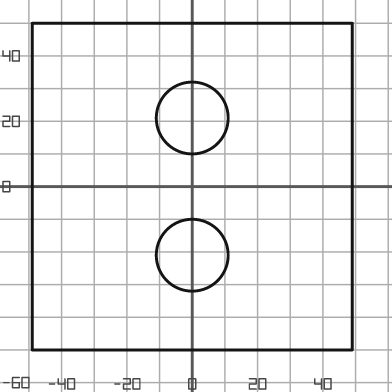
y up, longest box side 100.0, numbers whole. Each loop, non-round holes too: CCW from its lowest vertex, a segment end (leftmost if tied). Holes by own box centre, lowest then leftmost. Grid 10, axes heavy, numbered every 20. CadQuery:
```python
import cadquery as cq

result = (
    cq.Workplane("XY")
    .moveTo(-49.0, -50.0)
    .lineTo(49.0, -50.0)
    .lineTo(49.0, 50.0)
    .lineTo(-49.0, 50.0)
    .close()
    .moveTo(0.0, -21.0)
    .circle(11.0)
    .moveTo(0.0, 21.0)
    .circle(11.0)
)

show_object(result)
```